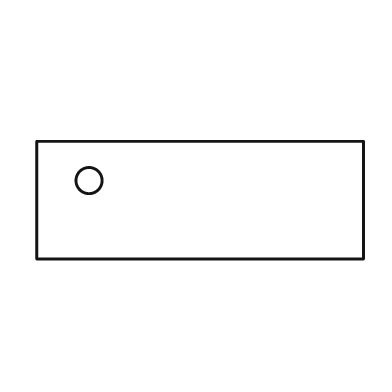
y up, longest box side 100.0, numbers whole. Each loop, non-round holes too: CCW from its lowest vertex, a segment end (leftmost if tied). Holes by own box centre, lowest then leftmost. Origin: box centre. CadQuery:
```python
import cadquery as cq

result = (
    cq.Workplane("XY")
    .moveTo(-50.0, -18.0)
    .lineTo(50.0, -18.0)
    .lineTo(50.0, 18.0)
    .lineTo(-50.0, 18.0)
    .close()
    .moveTo(-34.0, 6.0)
    .circle(4.0)
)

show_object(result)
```